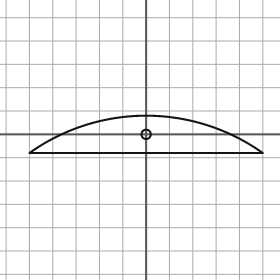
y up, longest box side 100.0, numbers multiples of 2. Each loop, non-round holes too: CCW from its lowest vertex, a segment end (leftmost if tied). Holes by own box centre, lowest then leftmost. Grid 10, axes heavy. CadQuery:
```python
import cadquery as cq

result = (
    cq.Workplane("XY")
    .moveTo(-50.0, -8.0)
    .lineTo(50.0, -8.0)
    .threePointArc((0.0, 8.0), (-50.0, -8.0))
    .close()
    .moveTo(0.0, 0.0)
    .circle(2.0)
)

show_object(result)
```